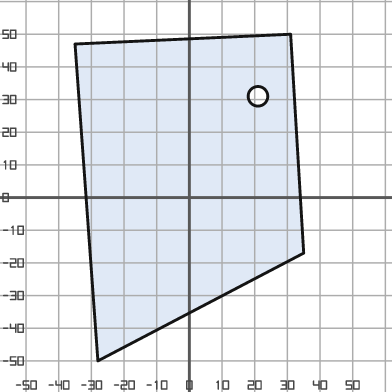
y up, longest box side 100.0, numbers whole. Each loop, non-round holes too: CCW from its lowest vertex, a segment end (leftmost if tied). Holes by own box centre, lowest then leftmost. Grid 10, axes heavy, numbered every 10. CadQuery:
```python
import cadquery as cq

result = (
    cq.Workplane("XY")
    .moveTo(-28.0, -50.0)
    .lineTo(35.0, -17.0)
    .lineTo(31.0, 50.0)
    .lineTo(-35.0, 47.0)
    .close()
    .moveTo(21.0, 31.0)
    .circle(3.0)
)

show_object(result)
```